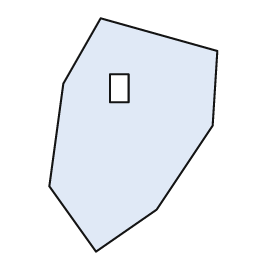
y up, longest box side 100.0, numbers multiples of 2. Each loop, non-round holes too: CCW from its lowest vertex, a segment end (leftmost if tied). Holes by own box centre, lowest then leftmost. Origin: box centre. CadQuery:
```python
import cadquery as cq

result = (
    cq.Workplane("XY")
    .moveTo(-16.0, -50.0)
    .lineTo(10.0, -32.0)
    .lineTo(34.0, 4.0)
    .lineTo(36.0, 36.0)
    .lineTo(-14.0, 50.0)
    .lineTo(-30.0, 22.0)
    .lineTo(-36.0, -22.0)
    .close()
    .moveTo(-10.0, 14.0)
    .lineTo(-2.0, 14.0)
    .lineTo(-2.0, 26.0)
    .lineTo(-10.0, 26.0)
    .close()
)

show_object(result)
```